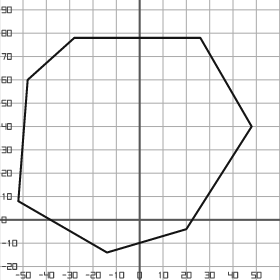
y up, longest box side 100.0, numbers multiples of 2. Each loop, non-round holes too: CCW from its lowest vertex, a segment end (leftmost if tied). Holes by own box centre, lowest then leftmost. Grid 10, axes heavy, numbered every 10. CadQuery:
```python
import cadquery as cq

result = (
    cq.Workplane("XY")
    .moveTo(-14.0, -14.0)
    .lineTo(20.0, -4.0)
    .lineTo(48.0, 40.0)
    .lineTo(26.0, 78.0)
    .lineTo(-28.0, 78.0)
    .lineTo(-48.0, 60.0)
    .lineTo(-52.0, 8.0)
    .close()
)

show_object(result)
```